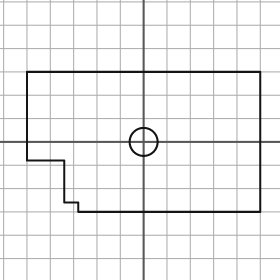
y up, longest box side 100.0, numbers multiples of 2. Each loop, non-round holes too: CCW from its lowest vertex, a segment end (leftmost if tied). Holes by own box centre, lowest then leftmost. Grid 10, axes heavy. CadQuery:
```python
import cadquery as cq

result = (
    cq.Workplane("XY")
    .moveTo(-28.0, -30.0)
    .lineTo(50.0, -30.0)
    .lineTo(50.0, 30.0)
    .lineTo(-50.0, 30.0)
    .lineTo(-50.0, -8.0)
    .lineTo(-34.0, -8.0)
    .lineTo(-34.0, -26.0)
    .lineTo(-28.0, -26.0)
    .close()
    .moveTo(0.0, 0.0)
    .circle(6.0)
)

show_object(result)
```